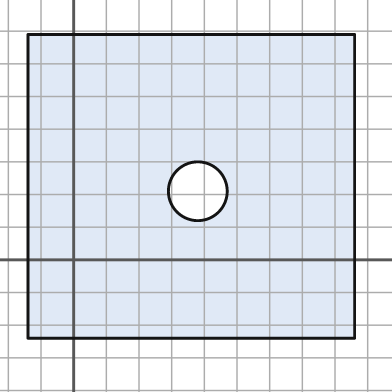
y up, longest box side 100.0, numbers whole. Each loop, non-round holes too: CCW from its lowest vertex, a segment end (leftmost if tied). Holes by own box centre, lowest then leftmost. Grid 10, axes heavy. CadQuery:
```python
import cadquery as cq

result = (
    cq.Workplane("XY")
    .moveTo(-14.0, -24.0)
    .lineTo(86.0, -24.0)
    .lineTo(86.0, 69.0)
    .lineTo(-14.0, 69.0)
    .close()
    .moveTo(38.0, 21.0)
    .circle(9.0)
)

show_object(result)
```